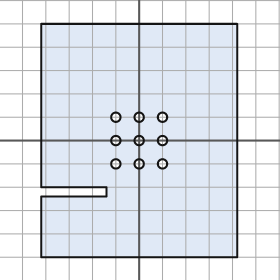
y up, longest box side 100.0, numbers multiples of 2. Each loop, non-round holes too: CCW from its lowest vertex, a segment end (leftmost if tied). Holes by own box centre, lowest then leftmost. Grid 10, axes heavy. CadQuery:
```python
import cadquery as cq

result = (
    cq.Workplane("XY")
    .moveTo(-42.0, -50.0)
    .lineTo(42.0, -50.0)
    .lineTo(42.0, 50.0)
    .lineTo(-42.0, 50.0)
    .lineTo(-42.0, -20.0)
    .lineTo(-14.0, -20.0)
    .lineTo(-14.0, -24.0)
    .lineTo(-42.0, -24.0)
    .close()
    .moveTo(-10.0, -10.0)
    .circle(2.0)
    .moveTo(0.0, -10.0)
    .circle(2.0)
    .moveTo(10.0, -10.0)
    .circle(2.0)
    .moveTo(-10.0, 0.0)
    .circle(2.0)
    .moveTo(0.0, 0.0)
    .circle(2.0)
    .moveTo(10.0, 0.0)
    .circle(2.0)
    .moveTo(-10.0, 10.0)
    .circle(2.0)
    .moveTo(0.0, 10.0)
    .circle(2.0)
    .moveTo(10.0, 10.0)
    .circle(2.0)
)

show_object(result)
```